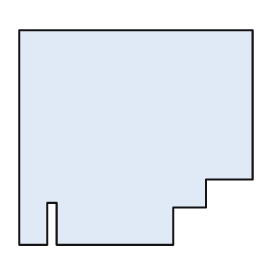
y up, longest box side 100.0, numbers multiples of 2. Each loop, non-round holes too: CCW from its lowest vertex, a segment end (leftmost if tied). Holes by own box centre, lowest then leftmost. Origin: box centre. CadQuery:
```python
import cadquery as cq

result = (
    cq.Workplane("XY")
    .moveTo(-50.0, -46.0)
    .lineTo(-38.0, -46.0)
    .lineTo(-38.0, -28.0)
    .lineTo(-34.0, -28.0)
    .lineTo(-34.0, -46.0)
    .lineTo(16.0, -46.0)
    .lineTo(16.0, -30.0)
    .lineTo(30.0, -30.0)
    .lineTo(30.0, -18.0)
    .lineTo(50.0, -18.0)
    .lineTo(50.0, 46.0)
    .lineTo(-50.0, 46.0)
    .close()
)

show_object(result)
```